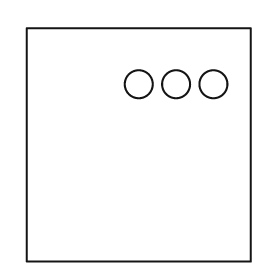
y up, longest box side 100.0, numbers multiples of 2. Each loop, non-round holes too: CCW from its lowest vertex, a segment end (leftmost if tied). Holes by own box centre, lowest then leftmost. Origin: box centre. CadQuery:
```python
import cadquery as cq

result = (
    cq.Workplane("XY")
    .moveTo(-48.0, -50.0)
    .lineTo(48.0, -50.0)
    .lineTo(48.0, 50.0)
    .lineTo(-48.0, 50.0)
    .close()
    .moveTo(0.0, 26.0)
    .circle(6.0)
    .moveTo(16.0, 26.0)
    .circle(6.0)
    .moveTo(32.0, 26.0)
    .circle(6.0)
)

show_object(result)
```